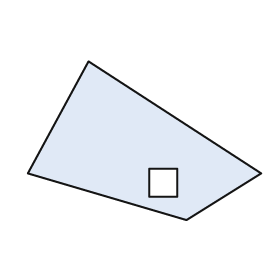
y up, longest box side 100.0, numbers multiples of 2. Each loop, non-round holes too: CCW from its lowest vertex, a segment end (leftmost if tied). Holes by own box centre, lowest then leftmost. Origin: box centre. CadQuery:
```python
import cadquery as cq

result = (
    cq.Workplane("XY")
    .moveTo(18.0, -34.0)
    .lineTo(50.0, -14.0)
    .lineTo(-24.0, 34.0)
    .lineTo(-50.0, -14.0)
    .close()
    .moveTo(2.0, -24.0)
    .lineTo(14.0, -24.0)
    .lineTo(14.0, -12.0)
    .lineTo(2.0, -12.0)
    .close()
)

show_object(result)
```